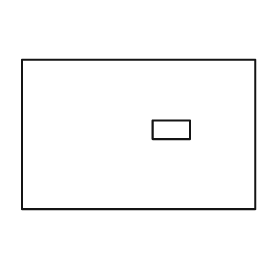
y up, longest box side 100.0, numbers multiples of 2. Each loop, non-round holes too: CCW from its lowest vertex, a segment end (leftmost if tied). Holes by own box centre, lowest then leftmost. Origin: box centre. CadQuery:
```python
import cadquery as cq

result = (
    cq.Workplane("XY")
    .moveTo(-50.0, -32.0)
    .lineTo(50.0, -32.0)
    .lineTo(50.0, 32.0)
    .lineTo(-50.0, 32.0)
    .close()
    .moveTo(6.0, -2.0)
    .lineTo(22.0, -2.0)
    .lineTo(22.0, 6.0)
    .lineTo(6.0, 6.0)
    .close()
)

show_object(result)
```